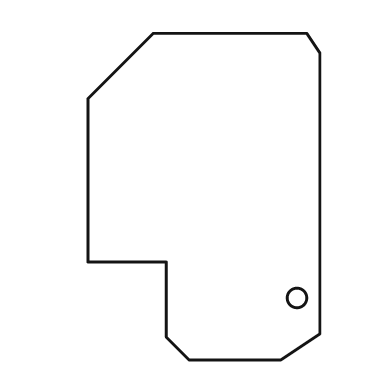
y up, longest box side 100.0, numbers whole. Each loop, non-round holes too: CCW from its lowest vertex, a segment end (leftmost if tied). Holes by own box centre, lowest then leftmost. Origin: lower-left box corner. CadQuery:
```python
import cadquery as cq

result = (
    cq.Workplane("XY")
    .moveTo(31.0, 0.0)
    .lineTo(59.0, 0.0)
    .lineTo(71.0, 8.0)
    .lineTo(71.0, 94.0)
    .lineTo(67.0, 100.0)
    .lineTo(20.0, 100.0)
    .lineTo(0.0, 80.0)
    .lineTo(0.0, 30.0)
    .lineTo(24.0, 30.0)
    .lineTo(24.0, 7.0)
    .close()
    .moveTo(64.0, 19.0)
    .circle(3.0)
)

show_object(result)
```